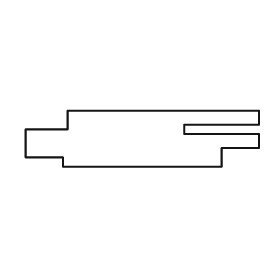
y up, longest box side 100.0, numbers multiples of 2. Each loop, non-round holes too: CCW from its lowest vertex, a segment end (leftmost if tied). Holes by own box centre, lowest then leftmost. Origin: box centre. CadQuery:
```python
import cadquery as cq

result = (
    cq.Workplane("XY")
    .moveTo(-34.0, -12.0)
    .lineTo(34.0, -12.0)
    .lineTo(34.0, -4.0)
    .lineTo(50.0, -4.0)
    .lineTo(50.0, 2.0)
    .lineTo(18.0, 2.0)
    .lineTo(18.0, 6.0)
    .lineTo(50.0, 6.0)
    .lineTo(50.0, 12.0)
    .lineTo(-32.0, 12.0)
    .lineTo(-32.0, 4.0)
    .lineTo(-50.0, 4.0)
    .lineTo(-50.0, -8.0)
    .lineTo(-34.0, -8.0)
    .close()
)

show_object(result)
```